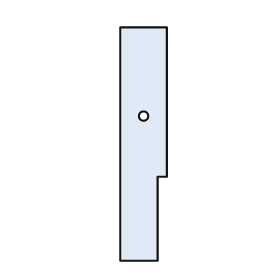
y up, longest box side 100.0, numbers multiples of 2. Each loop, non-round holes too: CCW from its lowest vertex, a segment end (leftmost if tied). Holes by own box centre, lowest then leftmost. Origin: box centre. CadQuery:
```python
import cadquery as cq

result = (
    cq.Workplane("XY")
    .moveTo(-10.0, -50.0)
    .lineTo(6.0, -50.0)
    .lineTo(6.0, -14.0)
    .lineTo(10.0, -14.0)
    .lineTo(10.0, 50.0)
    .lineTo(-10.0, 50.0)
    .close()
    .moveTo(0.0, 12.0)
    .circle(2.0)
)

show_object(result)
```